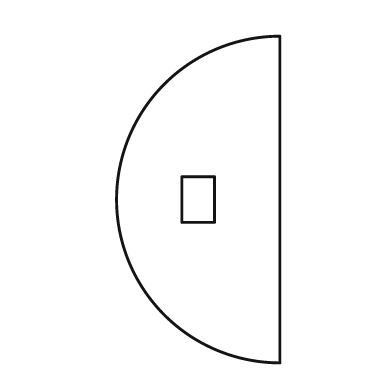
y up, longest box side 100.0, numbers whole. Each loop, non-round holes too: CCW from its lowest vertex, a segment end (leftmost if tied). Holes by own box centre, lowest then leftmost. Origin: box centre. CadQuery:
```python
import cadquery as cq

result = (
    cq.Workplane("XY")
    .moveTo(25.0, -50.0)
    .lineTo(25.0, 50.0)
    .threePointArc((-25.0, 0.0), (25.0, -50.0))
    .close()
    .moveTo(-5.0, -7.0)
    .lineTo(5.0, -7.0)
    .lineTo(5.0, 7.0)
    .lineTo(-5.0, 7.0)
    .close()
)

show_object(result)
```